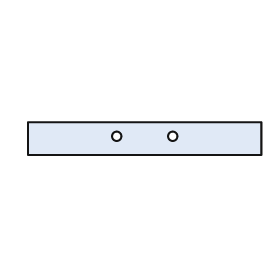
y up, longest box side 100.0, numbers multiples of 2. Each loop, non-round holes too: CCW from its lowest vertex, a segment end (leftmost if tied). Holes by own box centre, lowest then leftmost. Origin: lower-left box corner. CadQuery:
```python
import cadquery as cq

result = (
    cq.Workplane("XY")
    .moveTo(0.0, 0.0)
    .lineTo(100.0, 0.0)
    .lineTo(100.0, 14.0)
    .lineTo(0.0, 14.0)
    .close()
    .moveTo(38.0, 8.0)
    .circle(2.0)
    .moveTo(62.0, 8.0)
    .circle(2.0)
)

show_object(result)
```